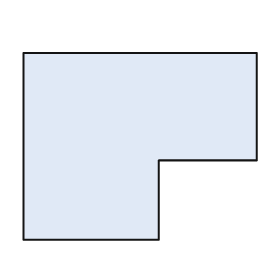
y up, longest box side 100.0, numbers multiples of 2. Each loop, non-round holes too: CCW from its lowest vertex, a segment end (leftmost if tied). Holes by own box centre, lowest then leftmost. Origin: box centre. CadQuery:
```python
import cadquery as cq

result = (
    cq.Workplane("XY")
    .moveTo(-50.0, -40.0)
    .lineTo(8.0, -40.0)
    .lineTo(8.0, -6.0)
    .lineTo(50.0, -6.0)
    .lineTo(50.0, 40.0)
    .lineTo(-50.0, 40.0)
    .close()
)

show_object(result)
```